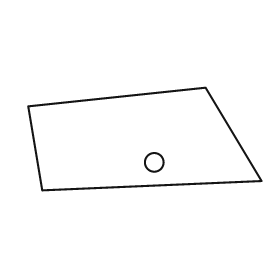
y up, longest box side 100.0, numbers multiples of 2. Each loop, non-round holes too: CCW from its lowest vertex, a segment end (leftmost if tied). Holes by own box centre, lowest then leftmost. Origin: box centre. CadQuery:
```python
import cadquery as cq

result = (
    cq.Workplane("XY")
    .moveTo(-44.0, -22.0)
    .lineTo(50.0, -18.0)
    .lineTo(26.0, 22.0)
    .lineTo(-50.0, 14.0)
    .close()
    .moveTo(4.0, -10.0)
    .circle(4.0)
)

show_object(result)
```